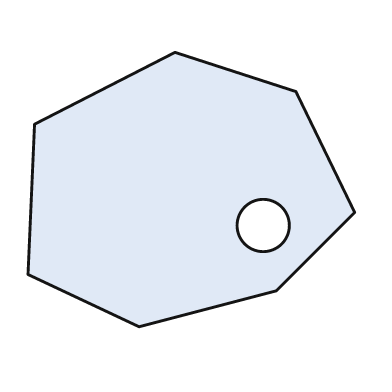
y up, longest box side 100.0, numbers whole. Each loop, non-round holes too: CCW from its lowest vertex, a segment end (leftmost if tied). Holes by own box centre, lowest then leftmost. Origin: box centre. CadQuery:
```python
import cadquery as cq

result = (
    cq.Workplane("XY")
    .moveTo(-16.0, -42.0)
    .lineTo(26.0, -31.0)
    .lineTo(50.0, -7.0)
    .lineTo(32.0, 30.0)
    .lineTo(-5.0, 42.0)
    .lineTo(-48.0, 20.0)
    .lineTo(-50.0, -26.0)
    .close()
    .moveTo(22.0, -11.0)
    .circle(8.0)
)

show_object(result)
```